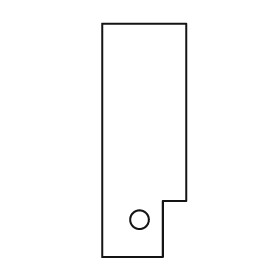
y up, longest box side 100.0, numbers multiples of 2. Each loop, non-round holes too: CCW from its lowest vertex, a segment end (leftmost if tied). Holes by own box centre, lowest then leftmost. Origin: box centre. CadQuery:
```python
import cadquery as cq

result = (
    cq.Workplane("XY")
    .moveTo(-18.0, -50.0)
    .lineTo(8.0, -50.0)
    .lineTo(8.0, -26.0)
    .lineTo(18.0, -26.0)
    .lineTo(18.0, 50.0)
    .lineTo(-18.0, 50.0)
    .close()
    .moveTo(-2.0, -34.0)
    .circle(4.0)
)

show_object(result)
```